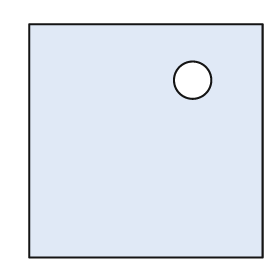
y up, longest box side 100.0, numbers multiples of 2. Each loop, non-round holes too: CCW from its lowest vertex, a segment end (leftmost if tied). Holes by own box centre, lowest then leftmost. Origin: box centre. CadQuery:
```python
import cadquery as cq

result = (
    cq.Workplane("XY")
    .moveTo(-50.0, -50.0)
    .lineTo(50.0, -50.0)
    .lineTo(50.0, 50.0)
    .lineTo(-50.0, 50.0)
    .close()
    .moveTo(20.0, 26.0)
    .circle(8.0)
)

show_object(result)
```